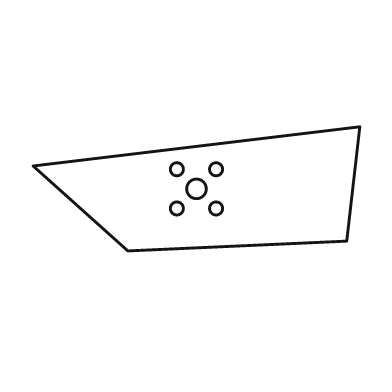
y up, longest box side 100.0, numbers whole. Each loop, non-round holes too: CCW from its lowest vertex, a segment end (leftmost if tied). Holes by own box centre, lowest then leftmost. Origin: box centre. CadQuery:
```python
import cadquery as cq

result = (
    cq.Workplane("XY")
    .moveTo(-21.0, -19.0)
    .lineTo(46.0, -16.0)
    .lineTo(50.0, 19.0)
    .lineTo(-50.0, 7.0)
    .close()
    .moveTo(-6.0, -6.0)
    .circle(2.0)
    .moveTo(6.0, -6.0)
    .circle(2.0)
    .moveTo(0.0, 0.0)
    .circle(3.0)
    .moveTo(-6.0, 6.0)
    .circle(2.0)
    .moveTo(6.0, 6.0)
    .circle(2.0)
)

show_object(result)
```